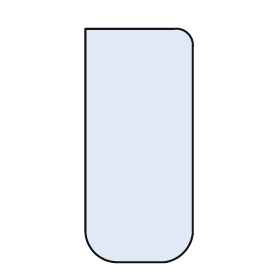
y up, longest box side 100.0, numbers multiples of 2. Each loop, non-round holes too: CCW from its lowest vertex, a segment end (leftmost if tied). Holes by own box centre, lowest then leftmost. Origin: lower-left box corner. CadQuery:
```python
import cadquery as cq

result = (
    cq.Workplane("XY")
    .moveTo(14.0, 0.0)
    .lineTo(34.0, 0.0)
    .threePointArc((42.0, 4.0), (46.0, 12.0))
    .lineTo(46.0, 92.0)
    .threePointArc((44.0, 98.0), (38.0, 100.0))
    .lineTo(0.0, 100.0)
    .lineTo(0.0, 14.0)
    .threePointArc((4.0, 4.0), (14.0, 0.0))
    .close()
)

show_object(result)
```